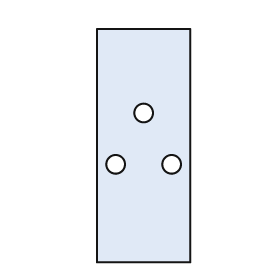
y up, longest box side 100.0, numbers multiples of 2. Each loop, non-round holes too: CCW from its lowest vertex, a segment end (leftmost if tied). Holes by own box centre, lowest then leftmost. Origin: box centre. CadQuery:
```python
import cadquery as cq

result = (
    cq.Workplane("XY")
    .moveTo(-20.0, -50.0)
    .lineTo(20.0, -50.0)
    .lineTo(20.0, 50.0)
    .lineTo(-20.0, 50.0)
    .close()
    .moveTo(-12.0, -8.0)
    .circle(4.0)
    .moveTo(12.0, -8.0)
    .circle(4.0)
    .moveTo(0.0, 14.0)
    .circle(4.0)
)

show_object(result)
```